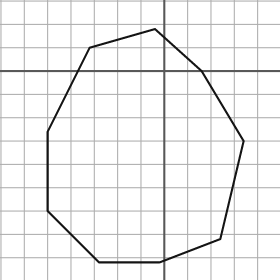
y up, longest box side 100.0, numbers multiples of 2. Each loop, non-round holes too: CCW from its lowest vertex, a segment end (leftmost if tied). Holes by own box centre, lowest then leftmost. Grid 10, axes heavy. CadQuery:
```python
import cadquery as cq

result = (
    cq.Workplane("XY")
    .moveTo(-28.0, -82.0)
    .lineTo(-2.0, -82.0)
    .lineTo(24.0, -72.0)
    .lineTo(34.0, -30.0)
    .lineTo(16.0, 0.0)
    .lineTo(-4.0, 18.0)
    .lineTo(-32.0, 10.0)
    .lineTo(-50.0, -26.0)
    .lineTo(-50.0, -60.0)
    .close()
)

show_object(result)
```